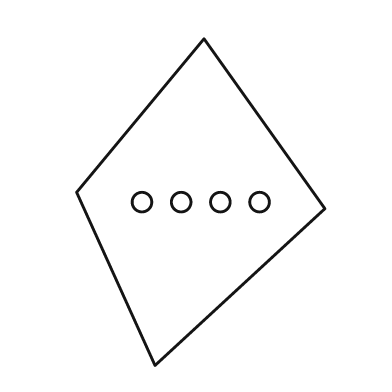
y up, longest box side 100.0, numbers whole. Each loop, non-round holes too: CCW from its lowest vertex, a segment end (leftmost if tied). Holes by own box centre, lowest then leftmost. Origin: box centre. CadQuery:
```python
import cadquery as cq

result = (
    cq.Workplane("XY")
    .moveTo(-14.0, -50.0)
    .lineTo(38.0, -2.0)
    .lineTo(1.0, 50.0)
    .lineTo(-38.0, 3.0)
    .close()
    .moveTo(-18.0, 0.0)
    .circle(3.0)
    .moveTo(-6.0, 0.0)
    .circle(3.0)
    .moveTo(6.0, 0.0)
    .circle(3.0)
    .moveTo(18.0, 0.0)
    .circle(3.0)
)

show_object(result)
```